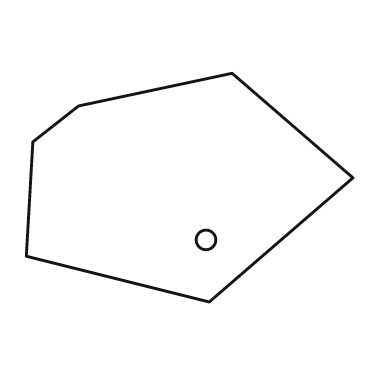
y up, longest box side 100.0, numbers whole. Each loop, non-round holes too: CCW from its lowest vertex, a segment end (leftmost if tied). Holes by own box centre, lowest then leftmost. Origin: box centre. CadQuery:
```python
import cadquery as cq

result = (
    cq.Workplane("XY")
    .moveTo(6.0, -35.0)
    .lineTo(50.0, 3.0)
    .lineTo(13.0, 35.0)
    .lineTo(-34.0, 25.0)
    .lineTo(-48.0, 14.0)
    .lineTo(-50.0, -21.0)
    .close()
    .moveTo(5.0, -16.0)
    .circle(3.0)
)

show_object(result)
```